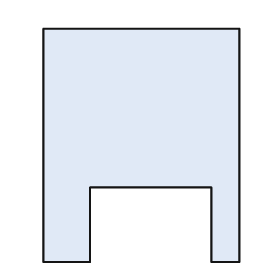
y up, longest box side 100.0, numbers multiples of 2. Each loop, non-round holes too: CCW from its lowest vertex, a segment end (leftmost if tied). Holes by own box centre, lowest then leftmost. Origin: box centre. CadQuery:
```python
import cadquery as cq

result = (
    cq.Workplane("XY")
    .moveTo(-42.0, -50.0)
    .lineTo(-22.0, -50.0)
    .lineTo(-22.0, -18.0)
    .lineTo(30.0, -18.0)
    .lineTo(30.0, -50.0)
    .lineTo(42.0, -50.0)
    .lineTo(42.0, 50.0)
    .lineTo(-42.0, 50.0)
    .close()
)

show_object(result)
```